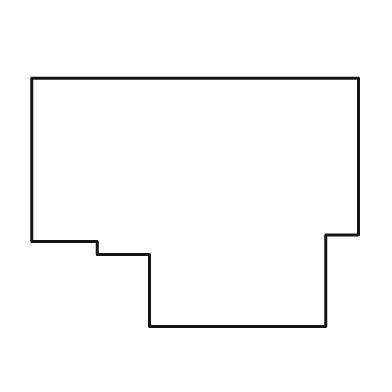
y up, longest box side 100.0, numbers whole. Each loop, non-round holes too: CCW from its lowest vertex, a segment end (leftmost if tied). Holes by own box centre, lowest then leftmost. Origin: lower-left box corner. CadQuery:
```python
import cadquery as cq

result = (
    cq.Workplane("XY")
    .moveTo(36.0, 0.0)
    .lineTo(90.0, 0.0)
    .lineTo(90.0, 28.0)
    .lineTo(100.0, 28.0)
    .lineTo(100.0, 76.0)
    .lineTo(0.0, 76.0)
    .lineTo(0.0, 26.0)
    .lineTo(20.0, 26.0)
    .lineTo(20.0, 22.0)
    .lineTo(36.0, 22.0)
    .close()
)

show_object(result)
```